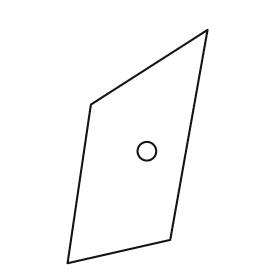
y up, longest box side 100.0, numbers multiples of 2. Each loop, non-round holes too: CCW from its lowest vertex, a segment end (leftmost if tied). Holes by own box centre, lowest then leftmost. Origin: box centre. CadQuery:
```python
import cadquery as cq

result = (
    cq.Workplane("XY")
    .moveTo(-30.0, -50.0)
    .lineTo(14.0, -40.0)
    .lineTo(30.0, 50.0)
    .lineTo(-20.0, 18.0)
    .close()
    .moveTo(4.0, -2.0)
    .circle(4.0)
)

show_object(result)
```